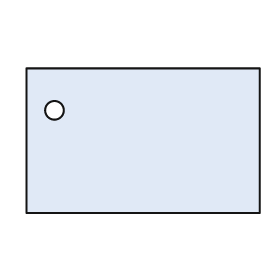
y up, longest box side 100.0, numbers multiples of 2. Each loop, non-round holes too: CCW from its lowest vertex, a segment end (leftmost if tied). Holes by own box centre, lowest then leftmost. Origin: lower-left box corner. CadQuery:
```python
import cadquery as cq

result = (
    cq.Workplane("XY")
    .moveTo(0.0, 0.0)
    .lineTo(100.0, 0.0)
    .lineTo(100.0, 62.0)
    .lineTo(0.0, 62.0)
    .close()
    .moveTo(12.0, 44.0)
    .circle(4.0)
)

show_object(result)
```